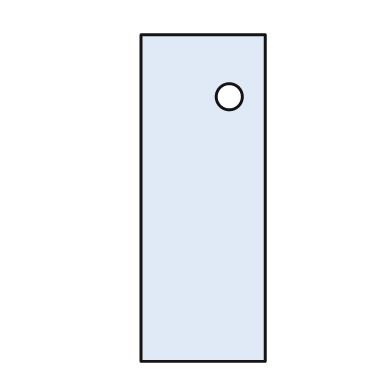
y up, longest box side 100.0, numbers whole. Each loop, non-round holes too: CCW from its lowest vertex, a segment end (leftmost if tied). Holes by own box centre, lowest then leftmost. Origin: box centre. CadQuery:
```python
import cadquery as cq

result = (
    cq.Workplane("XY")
    .moveTo(-19.0, -50.0)
    .lineTo(19.0, -50.0)
    .lineTo(19.0, 50.0)
    .lineTo(-19.0, 50.0)
    .close()
    .moveTo(8.0, 31.0)
    .circle(4.0)
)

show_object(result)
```